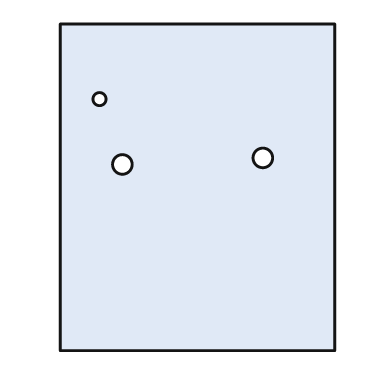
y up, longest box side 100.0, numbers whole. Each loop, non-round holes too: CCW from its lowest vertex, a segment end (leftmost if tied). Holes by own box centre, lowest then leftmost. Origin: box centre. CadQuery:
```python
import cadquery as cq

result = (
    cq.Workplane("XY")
    .moveTo(-42.0, -50.0)
    .lineTo(42.0, -50.0)
    .lineTo(42.0, 50.0)
    .lineTo(-42.0, 50.0)
    .close()
    .moveTo(-23.0, 7.0)
    .circle(3.0)
    .moveTo(20.0, 9.0)
    .circle(3.0)
    .moveTo(-30.0, 27.0)
    .circle(2.0)
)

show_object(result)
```